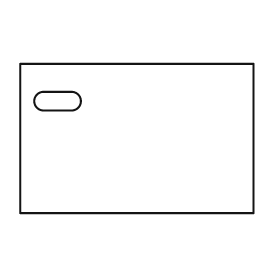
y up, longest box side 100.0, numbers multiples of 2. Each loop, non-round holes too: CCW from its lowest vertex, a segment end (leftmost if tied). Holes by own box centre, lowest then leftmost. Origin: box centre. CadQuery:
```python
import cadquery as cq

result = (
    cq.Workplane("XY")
    .moveTo(-50.0, -32.0)
    .lineTo(50.0, -32.0)
    .lineTo(50.0, 32.0)
    .lineTo(-50.0, 32.0)
    .close()
    .moveTo(-40.0, 12.0)
    .lineTo(-28.0, 12.0)
    .threePointArc((-24.0, 16.0), (-28.0, 20.0))
    .lineTo(-40.0, 20.0)
    .threePointArc((-44.0, 16.0), (-40.0, 12.0))
    .close()
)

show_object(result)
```